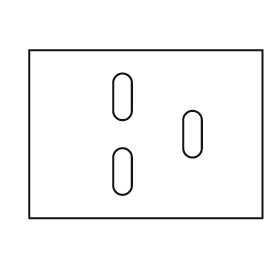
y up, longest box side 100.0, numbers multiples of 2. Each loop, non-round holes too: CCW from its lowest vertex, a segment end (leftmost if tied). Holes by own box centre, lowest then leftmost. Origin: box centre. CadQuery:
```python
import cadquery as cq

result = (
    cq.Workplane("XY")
    .moveTo(-50.0, -36.0)
    .lineTo(50.0, -36.0)
    .lineTo(50.0, 36.0)
    .lineTo(-50.0, 36.0)
    .close()
    .moveTo(-14.0, -22.0)
    .threePointArc((-10.0, -26.0), (-6.0, -22.0))
    .lineTo(-6.0, -10.0)
    .threePointArc((-10.0, -6.0), (-14.0, -10.0))
    .close()
    .moveTo(16.0, -6.0)
    .threePointArc((20.0, -10.0), (24.0, -6.0))
    .lineTo(24.0, 6.0)
    .threePointArc((20.0, 10.0), (16.0, 6.0))
    .close()
    .moveTo(-14.0, 10.0)
    .threePointArc((-10.0, 6.0), (-6.0, 10.0))
    .lineTo(-6.0, 22.0)
    .threePointArc((-10.0, 26.0), (-14.0, 22.0))
    .close()
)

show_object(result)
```